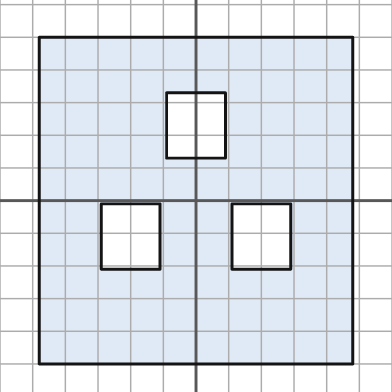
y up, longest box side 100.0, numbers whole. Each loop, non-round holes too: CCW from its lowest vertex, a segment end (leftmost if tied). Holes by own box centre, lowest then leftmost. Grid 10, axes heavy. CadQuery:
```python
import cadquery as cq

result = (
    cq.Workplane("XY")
    .moveTo(-48.0, -50.0)
    .lineTo(48.0, -50.0)
    .lineTo(48.0, 50.0)
    .lineTo(-48.0, 50.0)
    .close()
    .moveTo(-29.0, -21.0)
    .lineTo(-11.0, -21.0)
    .lineTo(-11.0, -1.0)
    .lineTo(-29.0, -1.0)
    .close()
    .moveTo(11.0, -21.0)
    .lineTo(29.0, -21.0)
    .lineTo(29.0, -1.0)
    .lineTo(11.0, -1.0)
    .close()
    .moveTo(-9.0, 13.0)
    .lineTo(9.0, 13.0)
    .lineTo(9.0, 33.0)
    .lineTo(-9.0, 33.0)
    .close()
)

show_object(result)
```